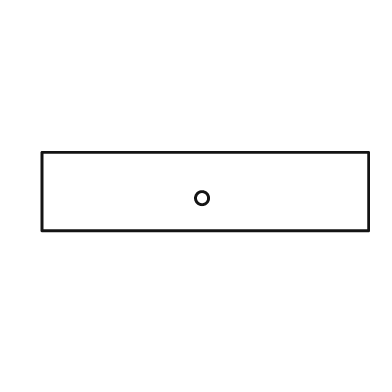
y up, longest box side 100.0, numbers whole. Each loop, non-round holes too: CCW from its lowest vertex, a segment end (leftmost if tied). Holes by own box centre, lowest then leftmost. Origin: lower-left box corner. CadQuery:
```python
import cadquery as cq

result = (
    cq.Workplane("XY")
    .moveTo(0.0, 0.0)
    .lineTo(100.0, 0.0)
    .lineTo(100.0, 24.0)
    .lineTo(0.0, 24.0)
    .close()
    .moveTo(49.0, 10.0)
    .circle(2.0)
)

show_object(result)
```